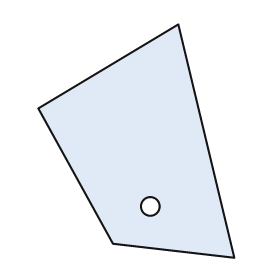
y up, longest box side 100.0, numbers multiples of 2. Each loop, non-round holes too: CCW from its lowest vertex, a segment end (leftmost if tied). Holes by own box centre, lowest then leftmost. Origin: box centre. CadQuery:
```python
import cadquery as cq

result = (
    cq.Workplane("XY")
    .moveTo(42.0, -50.0)
    .lineTo(18.0, 50.0)
    .lineTo(-42.0, 14.0)
    .lineTo(-10.0, -44.0)
    .close()
    .moveTo(6.0, -28.0)
    .circle(4.0)
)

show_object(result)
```